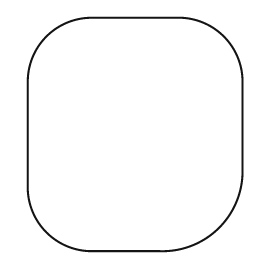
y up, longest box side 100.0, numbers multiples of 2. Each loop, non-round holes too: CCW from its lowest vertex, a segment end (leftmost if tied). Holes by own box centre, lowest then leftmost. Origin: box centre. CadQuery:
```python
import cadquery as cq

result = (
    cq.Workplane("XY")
    .moveTo(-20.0, -50.0)
    .lineTo(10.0, -50.0)
    .threePointArc((36.0, -40.0), (46.0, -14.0))
    .lineTo(46.0, 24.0)
    .threePointArc((38.0, 42.0), (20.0, 50.0))
    .lineTo(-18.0, 50.0)
    .threePointArc((-38.0, 42.0), (-46.0, 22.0))
    .lineTo(-46.0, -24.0)
    .threePointArc((-38.0, -42.0), (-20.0, -50.0))
    .close()
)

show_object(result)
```